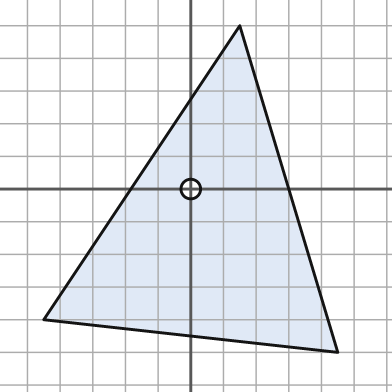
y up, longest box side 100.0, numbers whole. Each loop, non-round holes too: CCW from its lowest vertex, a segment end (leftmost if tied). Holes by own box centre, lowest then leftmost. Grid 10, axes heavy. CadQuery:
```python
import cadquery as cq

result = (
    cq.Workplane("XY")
    .moveTo(45.0, -50.0)
    .lineTo(15.0, 50.0)
    .lineTo(-45.0, -40.0)
    .close()
    .moveTo(0.0, 0.0)
    .circle(3.0)
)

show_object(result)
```